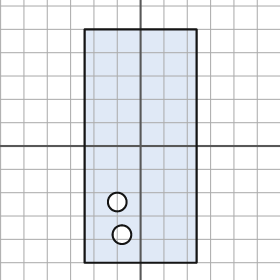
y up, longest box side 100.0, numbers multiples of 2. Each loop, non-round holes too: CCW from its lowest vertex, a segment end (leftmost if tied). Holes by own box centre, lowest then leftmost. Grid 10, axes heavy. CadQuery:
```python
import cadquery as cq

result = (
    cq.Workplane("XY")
    .moveTo(-24.0, -50.0)
    .lineTo(24.0, -50.0)
    .lineTo(24.0, 50.0)
    .lineTo(-24.0, 50.0)
    .close()
    .moveTo(-8.0, -38.0)
    .circle(4.0)
    .moveTo(-10.0, -24.0)
    .circle(4.0)
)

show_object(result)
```